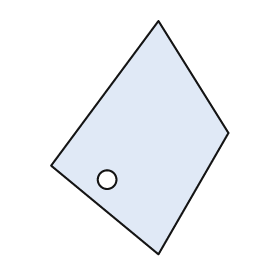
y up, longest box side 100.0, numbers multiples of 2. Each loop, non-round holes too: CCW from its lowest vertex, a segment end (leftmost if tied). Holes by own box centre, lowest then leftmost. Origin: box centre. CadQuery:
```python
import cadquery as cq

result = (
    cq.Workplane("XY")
    .moveTo(8.0, -50.0)
    .lineTo(38.0, 2.0)
    .lineTo(8.0, 50.0)
    .lineTo(-38.0, -12.0)
    .close()
    .moveTo(-14.0, -18.0)
    .circle(4.0)
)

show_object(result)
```